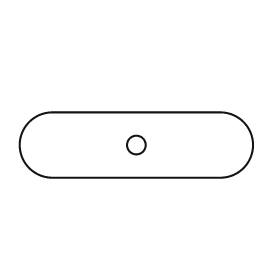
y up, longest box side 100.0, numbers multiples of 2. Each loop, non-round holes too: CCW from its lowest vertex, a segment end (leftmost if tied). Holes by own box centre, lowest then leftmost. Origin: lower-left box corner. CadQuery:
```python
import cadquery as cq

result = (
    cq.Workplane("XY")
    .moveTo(14.0, 0.0)
    .lineTo(86.0, 0.0)
    .threePointArc((100.0, 14.0), (86.0, 28.0))
    .lineTo(14.0, 28.0)
    .threePointArc((0.0, 14.0), (14.0, 0.0))
    .close()
    .moveTo(50.0, 14.0)
    .circle(4.0)
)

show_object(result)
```